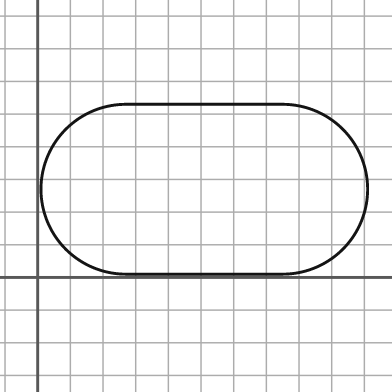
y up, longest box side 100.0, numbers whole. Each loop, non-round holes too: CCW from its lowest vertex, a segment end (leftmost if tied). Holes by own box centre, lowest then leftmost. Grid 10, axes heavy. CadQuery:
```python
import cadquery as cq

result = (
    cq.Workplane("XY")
    .moveTo(27.0, 1.0)
    .lineTo(75.0, 1.0)
    .threePointArc((101.0, 27.0), (75.0, 53.0))
    .lineTo(27.0, 53.0)
    .threePointArc((1.0, 27.0), (27.0, 1.0))
    .close()
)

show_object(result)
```